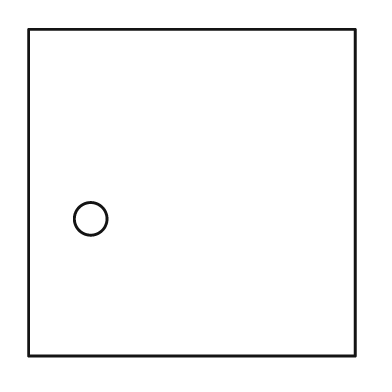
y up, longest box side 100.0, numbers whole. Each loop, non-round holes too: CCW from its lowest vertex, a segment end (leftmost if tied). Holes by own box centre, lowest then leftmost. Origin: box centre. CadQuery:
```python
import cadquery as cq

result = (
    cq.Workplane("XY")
    .moveTo(-50.0, -50.0)
    .lineTo(50.0, -50.0)
    .lineTo(50.0, 50.0)
    .lineTo(-50.0, 50.0)
    .close()
    .moveTo(-31.0, -8.0)
    .circle(5.0)
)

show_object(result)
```